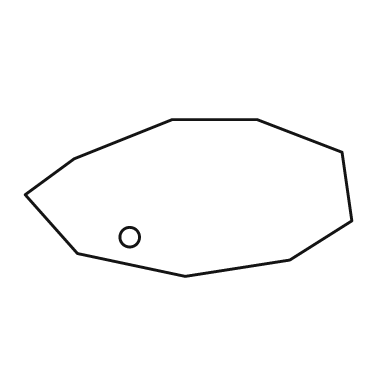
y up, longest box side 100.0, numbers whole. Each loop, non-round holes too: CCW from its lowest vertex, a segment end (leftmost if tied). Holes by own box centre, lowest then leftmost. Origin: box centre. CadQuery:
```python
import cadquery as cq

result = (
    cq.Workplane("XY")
    .moveTo(-1.0, -24.0)
    .lineTo(31.0, -19.0)
    .lineTo(50.0, -7.0)
    .lineTo(47.0, 14.0)
    .lineTo(21.0, 24.0)
    .lineTo(-5.0, 24.0)
    .lineTo(-35.0, 12.0)
    .lineTo(-50.0, 1.0)
    .lineTo(-34.0, -17.0)
    .close()
    .moveTo(-18.0, -12.0)
    .circle(3.0)
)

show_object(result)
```